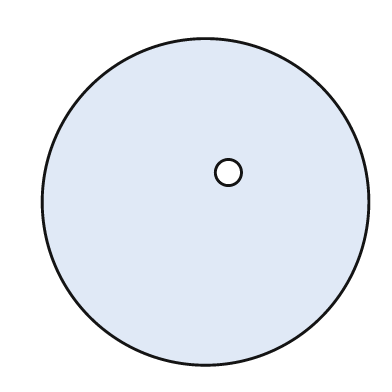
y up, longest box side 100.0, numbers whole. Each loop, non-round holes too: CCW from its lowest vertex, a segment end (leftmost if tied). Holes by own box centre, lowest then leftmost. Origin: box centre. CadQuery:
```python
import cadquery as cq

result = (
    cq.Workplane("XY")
    .moveTo(0.0, 0.0)
    .circle(50.0)
    .moveTo(7.0, 9.0)
    .circle(4.0)
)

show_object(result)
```